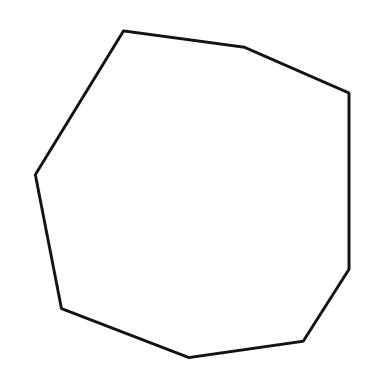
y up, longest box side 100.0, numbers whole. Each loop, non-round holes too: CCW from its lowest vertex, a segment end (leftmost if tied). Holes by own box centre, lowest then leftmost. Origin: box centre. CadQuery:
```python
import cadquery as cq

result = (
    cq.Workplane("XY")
    .moveTo(-1.0, -50.0)
    .lineTo(34.0, -45.0)
    .lineTo(48.0, -23.0)
    .lineTo(48.0, 31.0)
    .lineTo(16.0, 45.0)
    .lineTo(-21.0, 50.0)
    .lineTo(-48.0, 6.0)
    .lineTo(-40.0, -35.0)
    .close()
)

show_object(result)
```